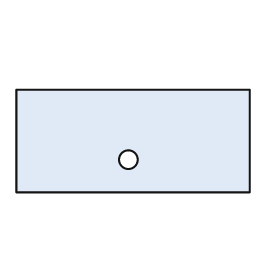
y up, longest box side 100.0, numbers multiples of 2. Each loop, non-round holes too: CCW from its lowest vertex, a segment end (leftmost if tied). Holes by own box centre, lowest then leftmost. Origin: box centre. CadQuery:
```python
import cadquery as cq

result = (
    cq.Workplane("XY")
    .moveTo(-50.0, -22.0)
    .lineTo(50.0, -22.0)
    .lineTo(50.0, 22.0)
    .lineTo(-50.0, 22.0)
    .close()
    .moveTo(-2.0, -8.0)
    .circle(4.0)
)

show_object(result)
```